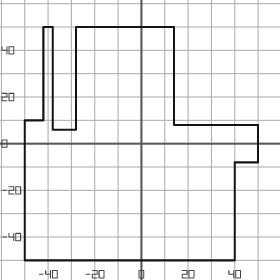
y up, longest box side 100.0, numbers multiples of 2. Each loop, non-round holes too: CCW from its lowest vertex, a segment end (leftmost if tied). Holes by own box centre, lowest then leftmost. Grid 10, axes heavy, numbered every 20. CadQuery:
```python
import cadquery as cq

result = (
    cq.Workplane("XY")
    .moveTo(-50.0, -50.0)
    .lineTo(40.0, -50.0)
    .lineTo(40.0, -8.0)
    .lineTo(50.0, -8.0)
    .lineTo(50.0, 8.0)
    .lineTo(14.0, 8.0)
    .lineTo(14.0, 50.0)
    .lineTo(-28.0, 50.0)
    .lineTo(-28.0, 6.0)
    .lineTo(-38.0, 6.0)
    .lineTo(-38.0, 50.0)
    .lineTo(-42.0, 50.0)
    .lineTo(-42.0, 10.0)
    .lineTo(-50.0, 10.0)
    .close()
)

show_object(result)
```